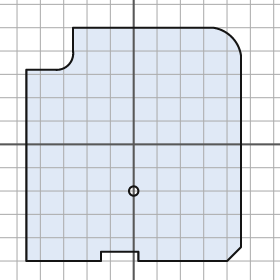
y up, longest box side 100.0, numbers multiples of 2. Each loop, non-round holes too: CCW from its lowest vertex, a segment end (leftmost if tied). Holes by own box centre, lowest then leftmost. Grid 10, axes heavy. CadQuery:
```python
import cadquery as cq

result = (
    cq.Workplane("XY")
    .moveTo(-46.0, -50.0)
    .lineTo(-14.0, -50.0)
    .lineTo(-14.0, -46.0)
    .lineTo(2.0, -46.0)
    .lineTo(2.0, -50.0)
    .lineTo(40.0, -50.0)
    .lineTo(46.0, -44.0)
    .lineTo(46.0, 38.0)
    .threePointArc((42.0, 46.0), (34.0, 50.0))
    .lineTo(-26.0, 50.0)
    .lineTo(-26.0, 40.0)
    .threePointArc((-28.0, 34.0), (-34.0, 32.0))
    .lineTo(-46.0, 32.0)
    .close()
    .moveTo(0.0, -20.0)
    .circle(2.0)
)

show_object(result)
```